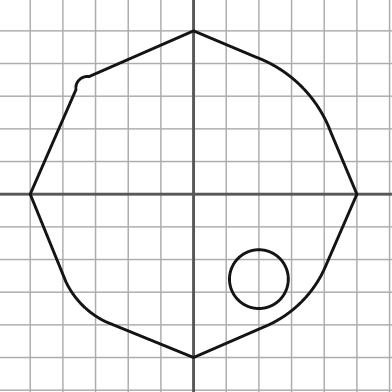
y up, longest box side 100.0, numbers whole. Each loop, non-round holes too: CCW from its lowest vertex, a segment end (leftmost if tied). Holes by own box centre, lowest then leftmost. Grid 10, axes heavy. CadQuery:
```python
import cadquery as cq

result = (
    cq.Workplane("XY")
    .moveTo(0.0, -50.0)
    .lineTo(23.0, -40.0)
    .threePointArc((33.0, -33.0), (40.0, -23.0))
    .lineTo(50.0, 0.0)
    .lineTo(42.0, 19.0)
    .threePointArc((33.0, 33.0), (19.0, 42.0))
    .lineTo(0.0, 50.0)
    .lineTo(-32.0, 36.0)
    .threePointArc((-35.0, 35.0), (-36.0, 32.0))
    .lineTo(-50.0, 0.0)
    .lineTo(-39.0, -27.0)
    .threePointArc((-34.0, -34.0), (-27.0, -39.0))
    .close()
    .moveTo(20.0, -26.0)
    .circle(9.0)
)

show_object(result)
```